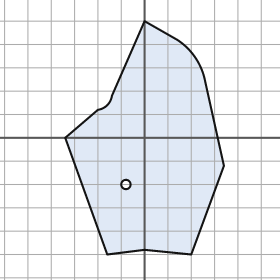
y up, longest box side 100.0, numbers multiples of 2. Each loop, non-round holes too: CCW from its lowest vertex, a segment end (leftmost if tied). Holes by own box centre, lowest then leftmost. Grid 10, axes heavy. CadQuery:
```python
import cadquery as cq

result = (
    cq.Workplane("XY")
    .moveTo(-16.0, -50.0)
    .lineTo(0.0, -48.0)
    .lineTo(20.0, -50.0)
    .lineTo(34.0, -12.0)
    .lineTo(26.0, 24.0)
    .threePointArc((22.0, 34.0), (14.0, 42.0))
    .lineTo(0.0, 50.0)
    .lineTo(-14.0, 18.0)
    .threePointArc((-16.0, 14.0), (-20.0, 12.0))
    .lineTo(-34.0, 0.0)
    .close()
    .moveTo(-8.0, -20.0)
    .circle(2.0)
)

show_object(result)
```